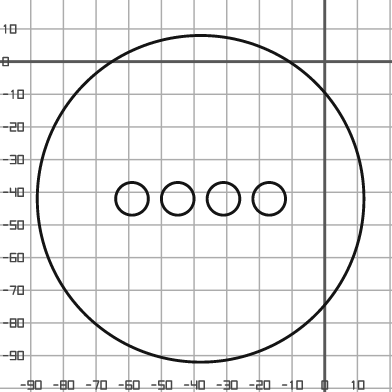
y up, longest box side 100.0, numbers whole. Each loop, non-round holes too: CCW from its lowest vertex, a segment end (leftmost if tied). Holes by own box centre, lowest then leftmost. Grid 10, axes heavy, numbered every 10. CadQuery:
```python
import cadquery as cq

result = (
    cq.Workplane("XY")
    .moveTo(-38.0, -42.0)
    .circle(50.0)
    .moveTo(-59.0, -42.0)
    .circle(5.0)
    .moveTo(-45.0, -42.0)
    .circle(5.0)
    .moveTo(-31.0, -42.0)
    .circle(5.0)
    .moveTo(-17.0, -42.0)
    .circle(5.0)
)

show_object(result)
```